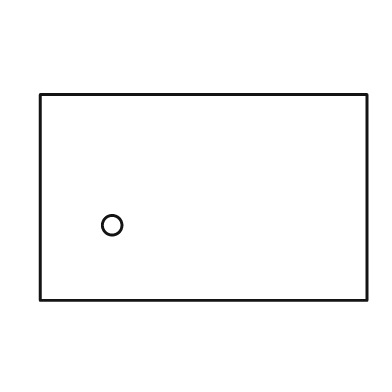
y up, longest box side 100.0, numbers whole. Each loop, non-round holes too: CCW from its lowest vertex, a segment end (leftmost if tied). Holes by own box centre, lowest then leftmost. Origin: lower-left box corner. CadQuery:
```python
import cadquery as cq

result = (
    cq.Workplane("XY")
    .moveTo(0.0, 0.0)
    .lineTo(100.0, 0.0)
    .lineTo(100.0, 63.0)
    .lineTo(0.0, 63.0)
    .close()
    .moveTo(22.0, 23.0)
    .circle(3.0)
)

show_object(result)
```